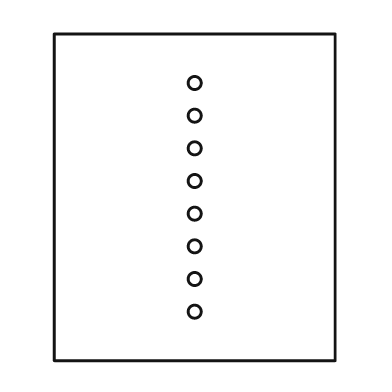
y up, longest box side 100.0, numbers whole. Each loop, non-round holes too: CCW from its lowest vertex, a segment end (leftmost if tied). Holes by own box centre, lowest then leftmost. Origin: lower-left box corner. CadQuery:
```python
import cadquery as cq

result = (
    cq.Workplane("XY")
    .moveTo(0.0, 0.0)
    .lineTo(86.0, 0.0)
    .lineTo(86.0, 100.0)
    .lineTo(0.0, 100.0)
    .close()
    .moveTo(43.0, 15.0)
    .circle(2.0)
    .moveTo(43.0, 25.0)
    .circle(2.0)
    .moveTo(43.0, 35.0)
    .circle(2.0)
    .moveTo(43.0, 45.0)
    .circle(2.0)
    .moveTo(43.0, 55.0)
    .circle(2.0)
    .moveTo(43.0, 65.0)
    .circle(2.0)
    .moveTo(43.0, 75.0)
    .circle(2.0)
    .moveTo(43.0, 85.0)
    .circle(2.0)
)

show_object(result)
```